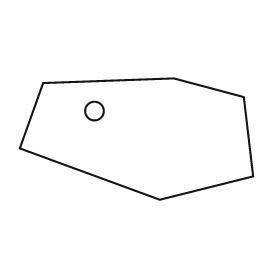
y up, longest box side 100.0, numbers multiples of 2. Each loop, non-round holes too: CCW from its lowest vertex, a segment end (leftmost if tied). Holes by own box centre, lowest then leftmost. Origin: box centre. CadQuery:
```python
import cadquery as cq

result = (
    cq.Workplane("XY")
    .moveTo(10.0, -26.0)
    .lineTo(50.0, -16.0)
    .lineTo(46.0, 18.0)
    .lineTo(16.0, 26.0)
    .lineTo(-40.0, 24.0)
    .lineTo(-50.0, -4.0)
    .close()
    .moveTo(-18.0, 12.0)
    .circle(4.0)
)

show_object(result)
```